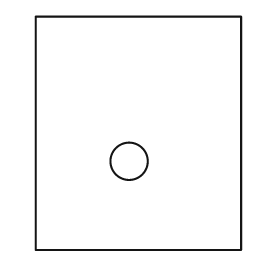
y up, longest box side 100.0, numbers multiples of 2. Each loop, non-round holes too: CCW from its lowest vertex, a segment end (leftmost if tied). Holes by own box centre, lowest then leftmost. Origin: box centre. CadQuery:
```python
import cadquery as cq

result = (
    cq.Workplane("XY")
    .moveTo(-44.0, -50.0)
    .lineTo(44.0, -50.0)
    .lineTo(44.0, 50.0)
    .lineTo(-44.0, 50.0)
    .close()
    .moveTo(-4.0, -12.0)
    .circle(8.0)
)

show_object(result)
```